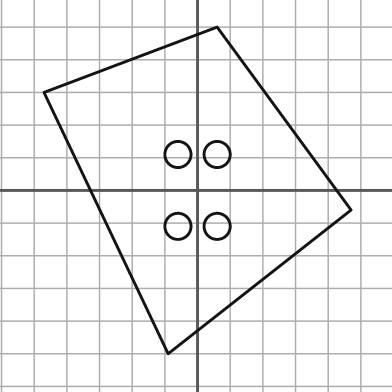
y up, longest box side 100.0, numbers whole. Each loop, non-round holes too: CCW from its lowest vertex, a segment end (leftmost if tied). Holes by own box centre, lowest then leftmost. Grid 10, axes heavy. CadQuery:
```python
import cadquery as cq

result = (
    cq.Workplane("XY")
    .moveTo(-9.0, -50.0)
    .lineTo(47.0, -6.0)
    .lineTo(6.0, 50.0)
    .lineTo(-47.0, 30.0)
    .close()
    .moveTo(-6.0, -11.0)
    .circle(4.0)
    .moveTo(6.0, -11.0)
    .circle(4.0)
    .moveTo(-6.0, 11.0)
    .circle(4.0)
    .moveTo(6.0, 11.0)
    .circle(4.0)
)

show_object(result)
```